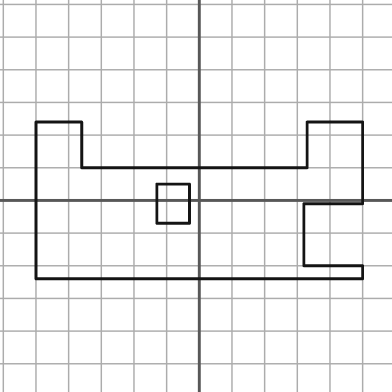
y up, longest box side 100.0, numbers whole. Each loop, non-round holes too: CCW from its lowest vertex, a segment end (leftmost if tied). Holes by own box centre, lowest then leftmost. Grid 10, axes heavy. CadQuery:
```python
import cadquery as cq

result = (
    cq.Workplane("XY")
    .moveTo(-50.0, -24.0)
    .lineTo(50.0, -24.0)
    .lineTo(50.0, -20.0)
    .lineTo(32.0, -20.0)
    .lineTo(32.0, -1.0)
    .lineTo(50.0, -1.0)
    .lineTo(50.0, 24.0)
    .lineTo(33.0, 24.0)
    .lineTo(33.0, 10.0)
    .lineTo(-36.0, 10.0)
    .lineTo(-36.0, 24.0)
    .lineTo(-50.0, 24.0)
    .close()
    .moveTo(-13.0, -7.0)
    .lineTo(-3.0, -7.0)
    .lineTo(-3.0, 5.0)
    .lineTo(-13.0, 5.0)
    .close()
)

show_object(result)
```